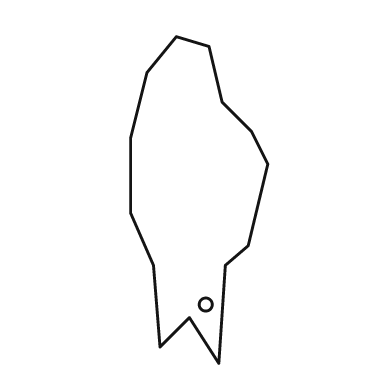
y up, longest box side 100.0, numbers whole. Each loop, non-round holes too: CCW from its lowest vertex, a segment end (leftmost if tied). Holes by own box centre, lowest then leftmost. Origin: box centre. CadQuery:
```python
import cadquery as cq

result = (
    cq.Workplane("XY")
    .moveTo(6.0, -50.0)
    .lineTo(8.0, -20.0)
    .lineTo(15.0, -14.0)
    .lineTo(21.0, 11.0)
    .lineTo(16.0, 21.0)
    .lineTo(7.0, 30.0)
    .lineTo(3.0, 47.0)
    .lineTo(-7.0, 50.0)
    .lineTo(-16.0, 39.0)
    .lineTo(-21.0, 19.0)
    .lineTo(-21.0, -4.0)
    .lineTo(-14.0, -20.0)
    .lineTo(-12.0, -45.0)
    .lineTo(-3.0, -36.0)
    .close()
    .moveTo(2.0, -32.0)
    .circle(2.0)
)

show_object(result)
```